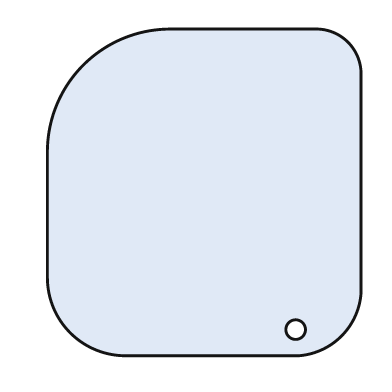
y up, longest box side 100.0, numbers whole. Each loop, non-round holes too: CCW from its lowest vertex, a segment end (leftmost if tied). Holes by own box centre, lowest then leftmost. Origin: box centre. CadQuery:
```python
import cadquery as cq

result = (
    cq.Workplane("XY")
    .moveTo(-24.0, -50.0)
    .lineTo(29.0, -50.0)
    .threePointArc((42.0, -44.0), (48.0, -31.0))
    .lineTo(48.0, 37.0)
    .threePointArc((44.0, 46.0), (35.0, 50.0))
    .lineTo(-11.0, 50.0)
    .threePointArc((-37.0, 39.0), (-48.0, 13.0))
    .lineTo(-48.0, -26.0)
    .threePointArc((-41.0, -43.0), (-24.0, -50.0))
    .close()
    .moveTo(28.0, -42.0)
    .circle(3.0)
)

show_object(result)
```